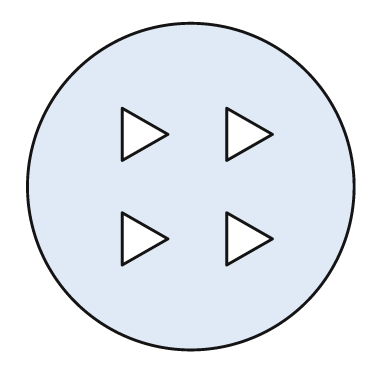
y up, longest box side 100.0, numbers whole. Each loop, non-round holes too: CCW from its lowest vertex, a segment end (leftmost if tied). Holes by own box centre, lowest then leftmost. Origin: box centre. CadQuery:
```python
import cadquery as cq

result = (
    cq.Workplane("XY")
    .moveTo(0.0, 0.0)
    .circle(50.0)
    .moveTo(-21.0, -24.0)
    .lineTo(-7.0, -16.0)
    .lineTo(-21.0, -8.0)
    .close()
    .moveTo(11.0, -24.0)
    .lineTo(25.0, -16.0)
    .lineTo(11.0, -8.0)
    .close()
    .moveTo(-21.0, 8.0)
    .lineTo(-7.0, 16.0)
    .lineTo(-21.0, 24.0)
    .close()
    .moveTo(11.0, 8.0)
    .lineTo(25.0, 16.0)
    .lineTo(11.0, 24.0)
    .close()
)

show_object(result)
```